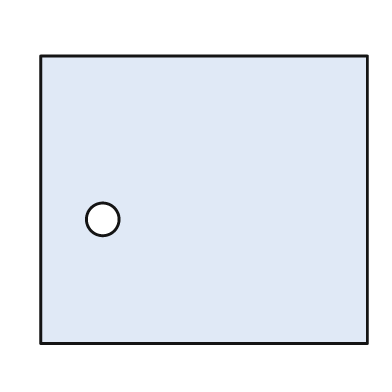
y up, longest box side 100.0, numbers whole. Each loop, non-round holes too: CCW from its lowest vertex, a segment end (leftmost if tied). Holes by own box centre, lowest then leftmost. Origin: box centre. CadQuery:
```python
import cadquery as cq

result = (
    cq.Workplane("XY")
    .moveTo(-50.0, -44.0)
    .lineTo(50.0, -44.0)
    .lineTo(50.0, 44.0)
    .lineTo(-50.0, 44.0)
    .close()
    .moveTo(-31.0, -6.0)
    .circle(5.0)
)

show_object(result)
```